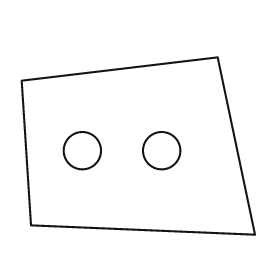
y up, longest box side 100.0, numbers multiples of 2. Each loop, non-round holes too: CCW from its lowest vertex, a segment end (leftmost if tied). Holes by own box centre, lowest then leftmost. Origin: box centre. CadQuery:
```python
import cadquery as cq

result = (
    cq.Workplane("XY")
    .moveTo(50.0, -38.0)
    .lineTo(34.0, 38.0)
    .lineTo(-50.0, 28.0)
    .lineTo(-46.0, -34.0)
    .close()
    .moveTo(-24.0, -2.0)
    .circle(8.0)
    .moveTo(10.0, -2.0)
    .circle(8.0)
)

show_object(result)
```